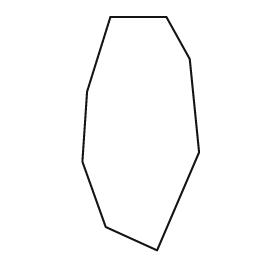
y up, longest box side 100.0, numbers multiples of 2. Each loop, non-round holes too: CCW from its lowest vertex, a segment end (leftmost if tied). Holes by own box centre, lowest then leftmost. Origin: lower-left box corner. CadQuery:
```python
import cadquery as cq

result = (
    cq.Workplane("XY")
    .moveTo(32.0, 0.0)
    .lineTo(50.0, 42.0)
    .lineTo(46.0, 82.0)
    .lineTo(36.0, 100.0)
    .lineTo(12.0, 100.0)
    .lineTo(2.0, 68.0)
    .lineTo(0.0, 38.0)
    .lineTo(10.0, 10.0)
    .close()
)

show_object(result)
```